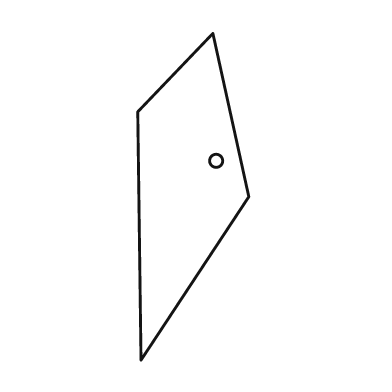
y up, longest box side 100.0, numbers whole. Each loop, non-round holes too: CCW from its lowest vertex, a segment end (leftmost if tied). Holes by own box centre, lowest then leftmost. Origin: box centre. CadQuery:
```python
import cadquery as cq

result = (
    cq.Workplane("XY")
    .moveTo(-16.0, -50.0)
    .lineTo(17.0, 0.0)
    .lineTo(6.0, 50.0)
    .lineTo(-17.0, 26.0)
    .close()
    .moveTo(7.0, 11.0)
    .circle(2.0)
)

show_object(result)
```